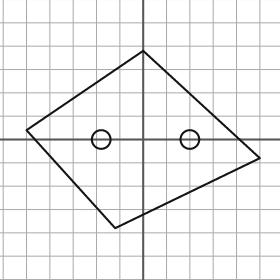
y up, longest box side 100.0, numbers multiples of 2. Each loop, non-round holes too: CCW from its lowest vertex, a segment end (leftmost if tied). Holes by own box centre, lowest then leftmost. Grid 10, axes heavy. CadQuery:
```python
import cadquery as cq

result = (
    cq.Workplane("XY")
    .moveTo(-12.0, -38.0)
    .lineTo(50.0, -8.0)
    .lineTo(0.0, 38.0)
    .lineTo(-50.0, 4.0)
    .close()
    .moveTo(-18.0, 0.0)
    .circle(4.0)
    .moveTo(20.0, 0.0)
    .circle(4.0)
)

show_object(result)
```